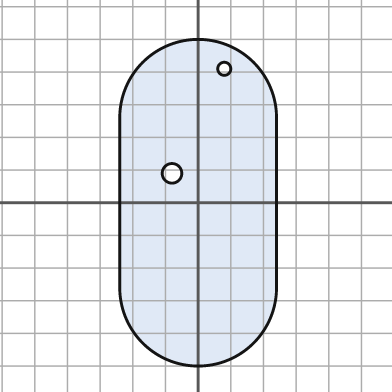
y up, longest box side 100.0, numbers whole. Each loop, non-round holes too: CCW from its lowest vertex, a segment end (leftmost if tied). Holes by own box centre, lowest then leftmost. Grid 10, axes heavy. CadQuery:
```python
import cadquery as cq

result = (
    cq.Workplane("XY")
    .moveTo(-24.0, -26.0)
    .threePointArc((0.0, -50.0), (24.0, -26.0))
    .lineTo(24.0, 26.0)
    .threePointArc((0.0, 50.0), (-24.0, 26.0))
    .close()
    .moveTo(-8.0, 9.0)
    .circle(3.0)
    .moveTo(8.0, 41.0)
    .circle(2.0)
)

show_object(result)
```